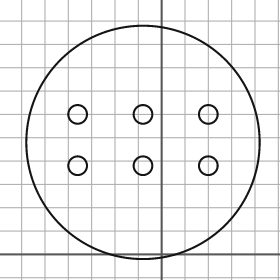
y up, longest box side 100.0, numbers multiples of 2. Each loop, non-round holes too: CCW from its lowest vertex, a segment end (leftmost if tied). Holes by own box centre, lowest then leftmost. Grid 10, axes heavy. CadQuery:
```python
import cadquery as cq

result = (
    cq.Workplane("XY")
    .moveTo(-8.0, 48.0)
    .circle(50.0)
    .moveTo(-36.0, 38.0)
    .circle(4.0)
    .moveTo(-8.0, 38.0)
    .circle(4.0)
    .moveTo(20.0, 38.0)
    .circle(4.0)
    .moveTo(-36.0, 60.0)
    .circle(4.0)
    .moveTo(-8.0, 60.0)
    .circle(4.0)
    .moveTo(20.0, 60.0)
    .circle(4.0)
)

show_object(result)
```